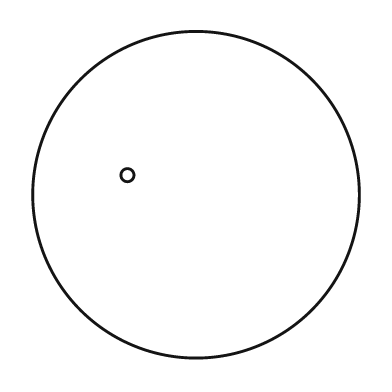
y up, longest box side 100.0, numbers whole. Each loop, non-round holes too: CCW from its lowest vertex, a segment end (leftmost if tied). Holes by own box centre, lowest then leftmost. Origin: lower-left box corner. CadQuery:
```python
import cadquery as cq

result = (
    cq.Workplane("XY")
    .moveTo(50.0, 50.0)
    .circle(50.0)
    .moveTo(29.0, 56.0)
    .circle(2.0)
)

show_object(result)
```